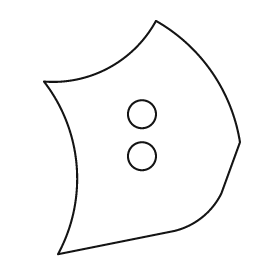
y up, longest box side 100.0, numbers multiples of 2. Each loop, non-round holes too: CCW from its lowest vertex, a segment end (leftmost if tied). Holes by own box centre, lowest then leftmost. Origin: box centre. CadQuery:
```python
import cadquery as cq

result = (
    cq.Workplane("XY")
    .moveTo(-36.0, -50.0)
    .lineTo(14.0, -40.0)
    .threePointArc((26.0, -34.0), (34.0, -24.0))
    .lineTo(42.0, -2.0)
    .threePointArc((30.0, 28.0), (6.0, 50.0))
    .threePointArc((-14.0, 30.0), (-42.0, 24.0))
    .threePointArc((-28.0, -12.0), (-36.0, -50.0))
    .close()
    .moveTo(0.0, -8.0)
    .circle(6.0)
    .moveTo(0.0, 10.0)
    .circle(6.0)
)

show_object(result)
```